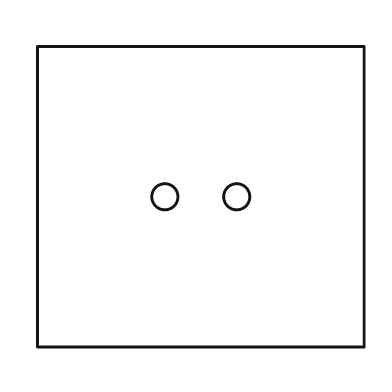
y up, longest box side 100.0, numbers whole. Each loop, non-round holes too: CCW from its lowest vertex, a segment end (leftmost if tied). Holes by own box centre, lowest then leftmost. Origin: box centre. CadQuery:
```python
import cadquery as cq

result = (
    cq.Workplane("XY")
    .moveTo(-50.0, -46.0)
    .lineTo(50.0, -46.0)
    .lineTo(50.0, 46.0)
    .lineTo(-50.0, 46.0)
    .close()
    .moveTo(-11.0, 0.0)
    .circle(4.0)
    .moveTo(11.0, 0.0)
    .circle(4.0)
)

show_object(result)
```